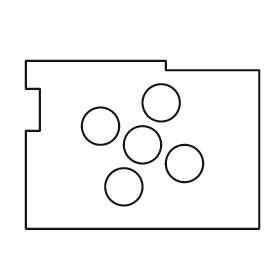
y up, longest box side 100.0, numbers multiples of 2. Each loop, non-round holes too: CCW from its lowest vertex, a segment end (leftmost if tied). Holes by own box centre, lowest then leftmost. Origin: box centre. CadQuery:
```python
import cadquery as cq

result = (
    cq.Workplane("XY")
    .moveTo(-50.0, -36.0)
    .lineTo(50.0, -36.0)
    .lineTo(50.0, 32.0)
    .lineTo(10.0, 32.0)
    .lineTo(10.0, 36.0)
    .lineTo(-50.0, 36.0)
    .lineTo(-50.0, 24.0)
    .lineTo(-44.0, 24.0)
    .lineTo(-44.0, 6.0)
    .lineTo(-50.0, 6.0)
    .close()
    .moveTo(-8.0, -18.0)
    .circle(8.0)
    .moveTo(18.0, -8.0)
    .circle(8.0)
    .moveTo(0.0, 0.0)
    .circle(8.0)
    .moveTo(-18.0, 8.0)
    .circle(8.0)
    .moveTo(8.0, 18.0)
    .circle(8.0)
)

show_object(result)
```